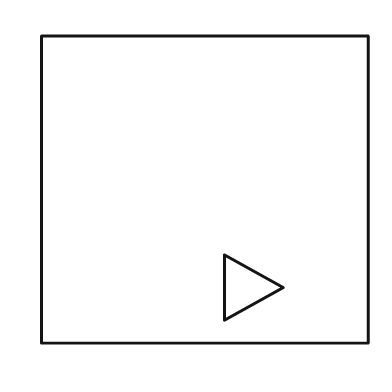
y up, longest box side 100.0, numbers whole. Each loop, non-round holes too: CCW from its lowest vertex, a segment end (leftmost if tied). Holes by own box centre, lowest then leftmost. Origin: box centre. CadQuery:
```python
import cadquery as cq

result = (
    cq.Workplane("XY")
    .moveTo(-50.0, -47.0)
    .lineTo(50.0, -47.0)
    .lineTo(50.0, 47.0)
    .lineTo(-50.0, 47.0)
    .close()
    .moveTo(6.0, -40.0)
    .lineTo(24.0, -30.0)
    .lineTo(6.0, -20.0)
    .close()
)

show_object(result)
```